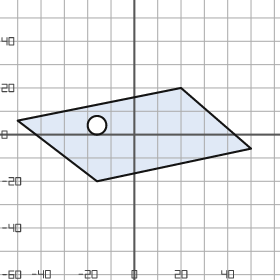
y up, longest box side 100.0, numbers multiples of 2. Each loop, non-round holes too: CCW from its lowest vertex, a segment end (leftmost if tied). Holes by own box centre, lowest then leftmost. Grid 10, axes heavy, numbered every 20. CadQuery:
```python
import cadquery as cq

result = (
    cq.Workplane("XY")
    .moveTo(-16.0, -20.0)
    .lineTo(50.0, -6.0)
    .lineTo(20.0, 20.0)
    .lineTo(-50.0, 6.0)
    .close()
    .moveTo(-16.0, 4.0)
    .circle(4.0)
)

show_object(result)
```